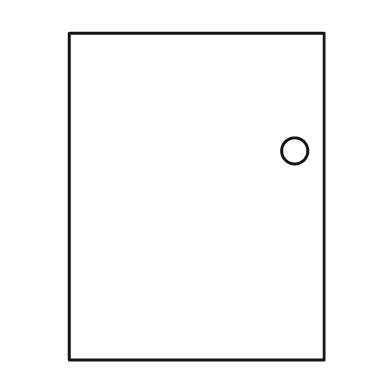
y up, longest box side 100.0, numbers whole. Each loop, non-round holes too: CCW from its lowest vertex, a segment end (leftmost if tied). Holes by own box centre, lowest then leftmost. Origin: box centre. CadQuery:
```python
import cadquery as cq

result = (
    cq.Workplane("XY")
    .moveTo(-39.0, -50.0)
    .lineTo(39.0, -50.0)
    .lineTo(39.0, 50.0)
    .lineTo(-39.0, 50.0)
    .close()
    .moveTo(30.0, 14.0)
    .circle(4.0)
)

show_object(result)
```